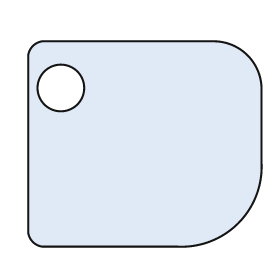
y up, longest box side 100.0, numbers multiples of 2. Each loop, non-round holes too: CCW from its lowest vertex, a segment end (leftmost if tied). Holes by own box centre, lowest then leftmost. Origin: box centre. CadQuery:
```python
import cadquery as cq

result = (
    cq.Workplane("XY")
    .moveTo(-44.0, -44.0)
    .lineTo(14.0, -44.0)
    .threePointArc((40.0, -34.0), (50.0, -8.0))
    .lineTo(50.0, 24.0)
    .threePointArc((44.0, 38.0), (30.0, 44.0))
    .lineTo(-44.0, 44.0)
    .threePointArc((-48.0, 42.0), (-50.0, 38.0))
    .lineTo(-50.0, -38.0)
    .threePointArc((-48.0, -42.0), (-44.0, -44.0))
    .close()
    .moveTo(-36.0, 24.0)
    .circle(10.0)
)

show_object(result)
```